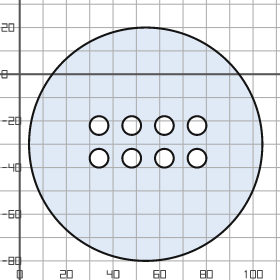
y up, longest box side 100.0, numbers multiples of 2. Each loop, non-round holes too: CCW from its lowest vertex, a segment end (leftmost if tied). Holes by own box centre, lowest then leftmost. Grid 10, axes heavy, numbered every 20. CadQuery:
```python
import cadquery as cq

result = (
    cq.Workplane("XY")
    .moveTo(54.0, -30.0)
    .circle(50.0)
    .moveTo(34.0, -36.0)
    .circle(4.0)
    .moveTo(48.0, -36.0)
    .circle(4.0)
    .moveTo(62.0, -36.0)
    .circle(4.0)
    .moveTo(76.0, -36.0)
    .circle(4.0)
    .moveTo(34.0, -22.0)
    .circle(4.0)
    .moveTo(48.0, -22.0)
    .circle(4.0)
    .moveTo(62.0, -22.0)
    .circle(4.0)
    .moveTo(76.0, -22.0)
    .circle(4.0)
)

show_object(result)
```